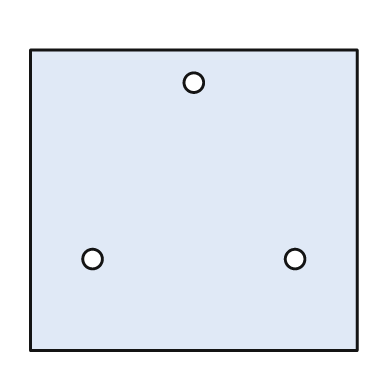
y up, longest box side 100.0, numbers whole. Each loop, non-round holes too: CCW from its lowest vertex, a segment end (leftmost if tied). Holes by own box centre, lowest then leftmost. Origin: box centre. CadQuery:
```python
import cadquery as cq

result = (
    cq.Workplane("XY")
    .moveTo(-50.0, -46.0)
    .lineTo(50.0, -46.0)
    .lineTo(50.0, 46.0)
    .lineTo(-50.0, 46.0)
    .close()
    .moveTo(-31.0, -18.0)
    .circle(3.0)
    .moveTo(31.0, -18.0)
    .circle(3.0)
    .moveTo(0.0, 36.0)
    .circle(3.0)
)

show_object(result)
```